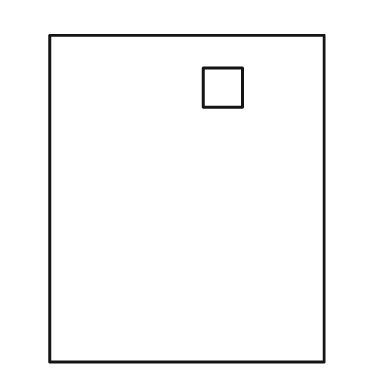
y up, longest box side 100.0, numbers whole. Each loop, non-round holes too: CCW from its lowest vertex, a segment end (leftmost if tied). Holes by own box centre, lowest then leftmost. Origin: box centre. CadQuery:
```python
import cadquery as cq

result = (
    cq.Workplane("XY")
    .moveTo(-42.0, -50.0)
    .lineTo(42.0, -50.0)
    .lineTo(42.0, 50.0)
    .lineTo(-42.0, 50.0)
    .close()
    .moveTo(5.0, 28.0)
    .lineTo(17.0, 28.0)
    .lineTo(17.0, 40.0)
    .lineTo(5.0, 40.0)
    .close()
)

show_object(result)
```